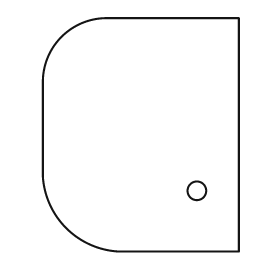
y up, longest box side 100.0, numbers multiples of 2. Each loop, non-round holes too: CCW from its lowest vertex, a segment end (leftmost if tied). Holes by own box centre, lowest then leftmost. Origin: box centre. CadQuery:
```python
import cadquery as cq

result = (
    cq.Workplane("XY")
    .moveTo(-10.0, -50.0)
    .lineTo(42.0, -50.0)
    .lineTo(42.0, 50.0)
    .lineTo(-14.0, 50.0)
    .threePointArc((-34.0, 42.0), (-42.0, 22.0))
    .lineTo(-42.0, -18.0)
    .threePointArc((-32.0, -40.0), (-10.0, -50.0))
    .close()
    .moveTo(24.0, -24.0)
    .circle(4.0)
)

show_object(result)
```